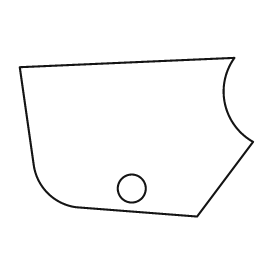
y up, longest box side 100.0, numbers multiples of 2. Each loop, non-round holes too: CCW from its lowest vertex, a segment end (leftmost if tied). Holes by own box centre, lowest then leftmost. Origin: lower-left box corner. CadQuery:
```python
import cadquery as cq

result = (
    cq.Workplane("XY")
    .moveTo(76.0, 0.0)
    .lineTo(100.0, 32.0)
    .threePointArc((88.0, 48.0), (92.0, 68.0))
    .lineTo(0.0, 64.0)
    .lineTo(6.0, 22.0)
    .threePointArc((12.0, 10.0), (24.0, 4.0))
    .close()
    .moveTo(48.0, 12.0)
    .circle(6.0)
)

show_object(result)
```